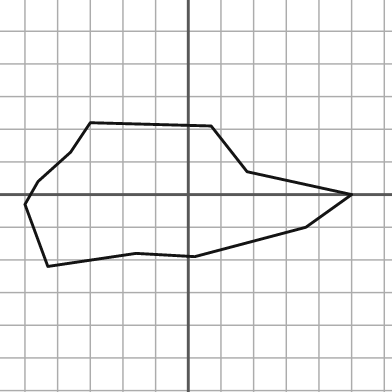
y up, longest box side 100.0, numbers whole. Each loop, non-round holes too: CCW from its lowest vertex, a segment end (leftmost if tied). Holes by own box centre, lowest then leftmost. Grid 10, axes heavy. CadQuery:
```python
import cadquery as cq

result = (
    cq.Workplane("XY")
    .moveTo(-43.0, -22.0)
    .lineTo(-16.0, -18.0)
    .lineTo(2.0, -19.0)
    .lineTo(36.0, -10.0)
    .lineTo(50.0, 0.0)
    .lineTo(18.0, 7.0)
    .lineTo(7.0, 21.0)
    .lineTo(-30.0, 22.0)
    .lineTo(-36.0, 13.0)
    .lineTo(-46.0, 4.0)
    .lineTo(-50.0, -3.0)
    .close()
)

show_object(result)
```